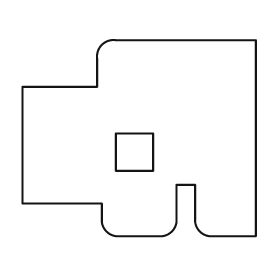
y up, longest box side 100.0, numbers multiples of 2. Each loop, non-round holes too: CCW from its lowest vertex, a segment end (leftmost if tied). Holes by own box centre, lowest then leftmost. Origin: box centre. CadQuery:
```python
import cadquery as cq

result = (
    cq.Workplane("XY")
    .moveTo(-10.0, -42.0)
    .lineTo(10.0, -42.0)
    .threePointArc((14.0, -40.0), (16.0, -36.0))
    .lineTo(16.0, -20.0)
    .lineTo(24.0, -20.0)
    .lineTo(24.0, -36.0)
    .threePointArc((26.0, -40.0), (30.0, -42.0))
    .lineTo(50.0, -42.0)
    .lineTo(50.0, 42.0)
    .lineTo(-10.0, 42.0)
    .threePointArc((-16.0, 40.0), (-18.0, 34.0))
    .lineTo(-18.0, 22.0)
    .lineTo(-50.0, 22.0)
    .lineTo(-50.0, -28.0)
    .lineTo(-16.0, -28.0)
    .lineTo(-16.0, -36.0)
    .threePointArc((-14.0, -40.0), (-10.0, -42.0))
    .close()
    .moveTo(-10.0, -14.0)
    .lineTo(6.0, -14.0)
    .lineTo(6.0, 2.0)
    .lineTo(-10.0, 2.0)
    .close()
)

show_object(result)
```